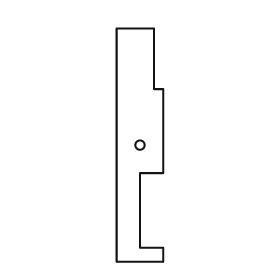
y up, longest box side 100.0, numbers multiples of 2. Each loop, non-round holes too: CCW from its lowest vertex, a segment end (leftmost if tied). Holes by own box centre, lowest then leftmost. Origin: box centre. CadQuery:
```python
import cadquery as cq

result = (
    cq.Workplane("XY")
    .moveTo(-10.0, -50.0)
    .lineTo(10.0, -50.0)
    .lineTo(10.0, -44.0)
    .lineTo(0.0, -44.0)
    .lineTo(0.0, -12.0)
    .lineTo(10.0, -12.0)
    .lineTo(10.0, 24.0)
    .lineTo(6.0, 24.0)
    .lineTo(6.0, 50.0)
    .lineTo(-10.0, 50.0)
    .close()
    .moveTo(0.0, 0.0)
    .circle(2.0)
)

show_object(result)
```